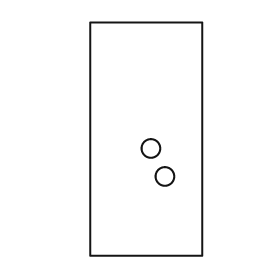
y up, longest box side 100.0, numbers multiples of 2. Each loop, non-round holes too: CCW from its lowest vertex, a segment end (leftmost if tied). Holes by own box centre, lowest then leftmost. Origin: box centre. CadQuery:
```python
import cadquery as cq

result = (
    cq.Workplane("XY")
    .moveTo(-24.0, -50.0)
    .lineTo(24.0, -50.0)
    .lineTo(24.0, 50.0)
    .lineTo(-24.0, 50.0)
    .close()
    .moveTo(8.0, -16.0)
    .circle(4.0)
    .moveTo(2.0, -4.0)
    .circle(4.0)
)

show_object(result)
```